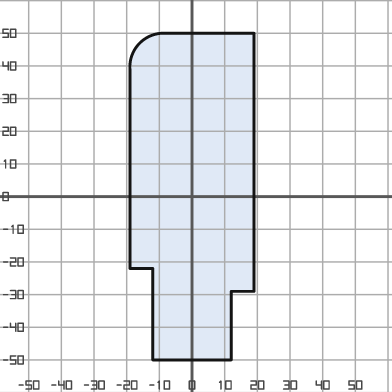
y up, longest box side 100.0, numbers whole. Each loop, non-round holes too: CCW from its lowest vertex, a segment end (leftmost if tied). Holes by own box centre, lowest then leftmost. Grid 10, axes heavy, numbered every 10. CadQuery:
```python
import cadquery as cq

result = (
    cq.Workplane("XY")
    .moveTo(-12.0, -50.0)
    .lineTo(12.0, -50.0)
    .lineTo(12.0, -29.0)
    .lineTo(19.0, -29.0)
    .lineTo(19.0, 50.0)
    .lineTo(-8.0, 50.0)
    .threePointArc((-16.0, 47.0), (-19.0, 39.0))
    .lineTo(-19.0, -22.0)
    .lineTo(-12.0, -22.0)
    .close()
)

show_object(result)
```